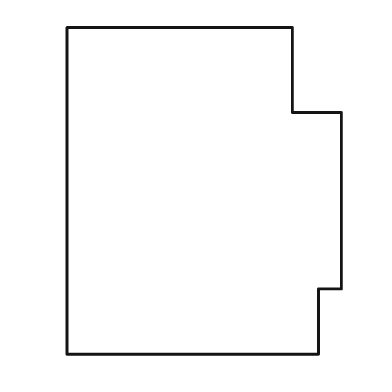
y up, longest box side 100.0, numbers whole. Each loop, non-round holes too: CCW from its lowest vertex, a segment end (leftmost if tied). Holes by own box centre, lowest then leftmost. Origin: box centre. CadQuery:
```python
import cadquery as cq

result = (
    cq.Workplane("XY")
    .moveTo(-42.0, -50.0)
    .lineTo(35.0, -50.0)
    .lineTo(35.0, -30.0)
    .lineTo(42.0, -30.0)
    .lineTo(42.0, 24.0)
    .lineTo(27.0, 24.0)
    .lineTo(27.0, 50.0)
    .lineTo(-42.0, 50.0)
    .close()
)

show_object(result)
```